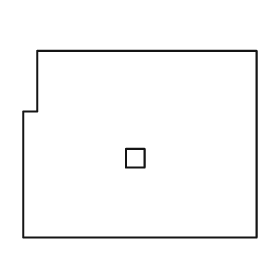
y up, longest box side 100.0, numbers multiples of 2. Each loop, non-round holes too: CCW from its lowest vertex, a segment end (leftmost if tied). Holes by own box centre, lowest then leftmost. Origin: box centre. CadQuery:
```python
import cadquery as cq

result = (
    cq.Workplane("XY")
    .moveTo(-50.0, -40.0)
    .lineTo(50.0, -40.0)
    .lineTo(50.0, 40.0)
    .lineTo(-44.0, 40.0)
    .lineTo(-44.0, 14.0)
    .lineTo(-50.0, 14.0)
    .close()
    .moveTo(-6.0, -10.0)
    .lineTo(2.0, -10.0)
    .lineTo(2.0, -2.0)
    .lineTo(-6.0, -2.0)
    .close()
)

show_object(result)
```